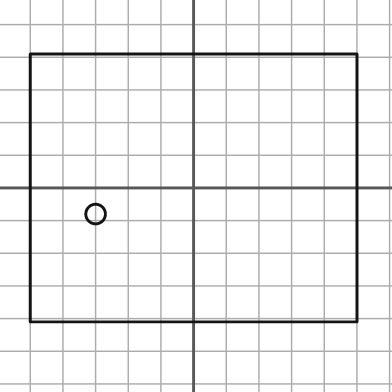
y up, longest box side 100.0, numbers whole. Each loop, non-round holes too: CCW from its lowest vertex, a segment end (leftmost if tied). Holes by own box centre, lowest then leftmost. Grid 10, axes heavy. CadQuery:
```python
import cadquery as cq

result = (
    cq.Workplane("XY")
    .moveTo(-50.0, -41.0)
    .lineTo(50.0, -41.0)
    .lineTo(50.0, 41.0)
    .lineTo(-50.0, 41.0)
    .close()
    .moveTo(-30.0, -8.0)
    .circle(3.0)
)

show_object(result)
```